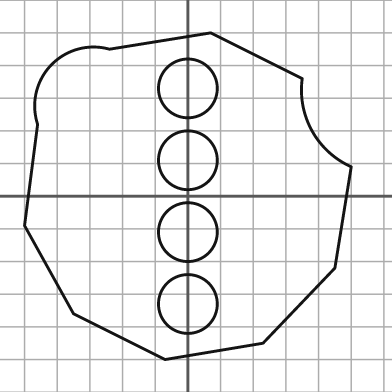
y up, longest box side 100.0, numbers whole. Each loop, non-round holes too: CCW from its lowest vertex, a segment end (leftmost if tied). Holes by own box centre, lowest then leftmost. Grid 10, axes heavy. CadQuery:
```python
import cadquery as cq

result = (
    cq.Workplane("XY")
    .moveTo(-7.0, -50.0)
    .lineTo(23.0, -45.0)
    .lineTo(45.0, -22.0)
    .lineTo(50.0, 9.0)
    .threePointArc((38.0, 20.0), (35.0, 36.0))
    .lineTo(7.0, 50.0)
    .lineTo(-24.0, 45.0)
    .threePointArc((-42.0, 40.0), (-46.0, 22.0))
    .lineTo(-50.0, -9.0)
    .lineTo(-35.0, -36.0)
    .close()
    .moveTo(0.0, -33.0)
    .circle(9.0)
    .moveTo(0.0, -11.0)
    .circle(9.0)
    .moveTo(0.0, 11.0)
    .circle(9.0)
    .moveTo(0.0, 33.0)
    .circle(9.0)
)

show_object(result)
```